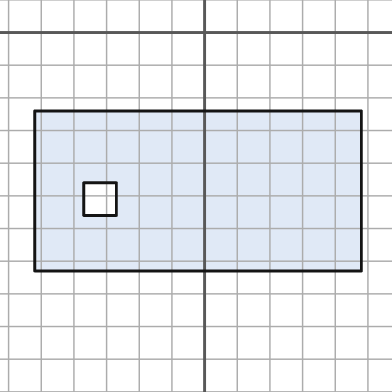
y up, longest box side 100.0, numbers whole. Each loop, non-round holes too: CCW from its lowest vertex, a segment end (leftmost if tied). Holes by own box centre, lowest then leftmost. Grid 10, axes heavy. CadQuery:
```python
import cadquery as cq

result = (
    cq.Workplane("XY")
    .moveTo(-52.0, -73.0)
    .lineTo(48.0, -73.0)
    .lineTo(48.0, -24.0)
    .lineTo(-52.0, -24.0)
    .close()
    .moveTo(-37.0, -56.0)
    .lineTo(-27.0, -56.0)
    .lineTo(-27.0, -46.0)
    .lineTo(-37.0, -46.0)
    .close()
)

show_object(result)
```